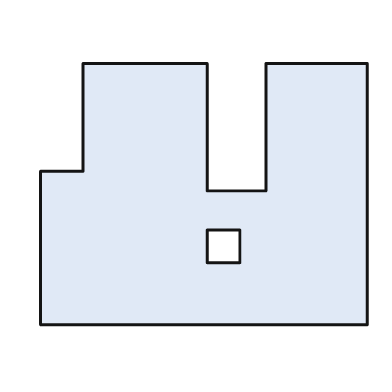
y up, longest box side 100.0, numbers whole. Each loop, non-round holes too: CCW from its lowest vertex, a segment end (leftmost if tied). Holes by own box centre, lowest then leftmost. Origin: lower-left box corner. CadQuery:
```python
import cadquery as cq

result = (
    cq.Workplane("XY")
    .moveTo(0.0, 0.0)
    .lineTo(100.0, 0.0)
    .lineTo(100.0, 80.0)
    .lineTo(69.0, 80.0)
    .lineTo(69.0, 41.0)
    .lineTo(51.0, 41.0)
    .lineTo(51.0, 80.0)
    .lineTo(13.0, 80.0)
    .lineTo(13.0, 47.0)
    .lineTo(0.0, 47.0)
    .close()
    .moveTo(51.0, 19.0)
    .lineTo(61.0, 19.0)
    .lineTo(61.0, 29.0)
    .lineTo(51.0, 29.0)
    .close()
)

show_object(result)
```